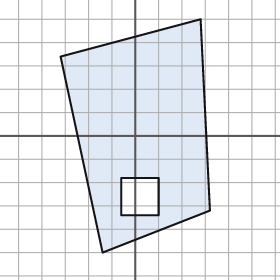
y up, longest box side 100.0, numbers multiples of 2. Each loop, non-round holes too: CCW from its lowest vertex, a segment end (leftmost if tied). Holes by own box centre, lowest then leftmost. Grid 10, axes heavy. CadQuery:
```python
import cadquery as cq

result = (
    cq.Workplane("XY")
    .moveTo(-14.0, -50.0)
    .lineTo(32.0, -32.0)
    .lineTo(28.0, 50.0)
    .lineTo(-32.0, 34.0)
    .close()
    .moveTo(-6.0, -34.0)
    .lineTo(10.0, -34.0)
    .lineTo(10.0, -18.0)
    .lineTo(-6.0, -18.0)
    .close()
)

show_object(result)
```